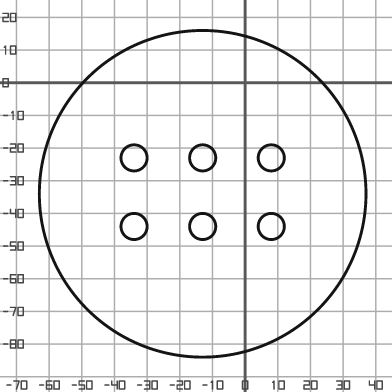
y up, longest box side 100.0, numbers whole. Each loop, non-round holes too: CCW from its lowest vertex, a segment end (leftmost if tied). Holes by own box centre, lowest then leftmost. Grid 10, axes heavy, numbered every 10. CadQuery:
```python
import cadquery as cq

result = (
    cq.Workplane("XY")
    .moveTo(-13.0, -34.0)
    .circle(50.0)
    .moveTo(-34.0, -44.0)
    .circle(4.0)
    .moveTo(-13.0, -44.0)
    .circle(4.0)
    .moveTo(8.0, -44.0)
    .circle(4.0)
    .moveTo(-34.0, -23.0)
    .circle(4.0)
    .moveTo(-13.0, -23.0)
    .circle(4.0)
    .moveTo(8.0, -23.0)
    .circle(4.0)
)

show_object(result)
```